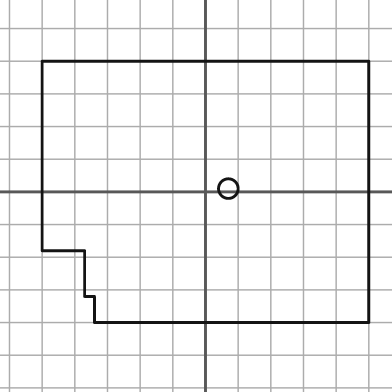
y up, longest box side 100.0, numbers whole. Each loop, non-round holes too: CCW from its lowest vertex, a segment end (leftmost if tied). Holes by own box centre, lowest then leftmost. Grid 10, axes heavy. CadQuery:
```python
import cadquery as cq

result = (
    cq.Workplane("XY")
    .moveTo(-34.0, -40.0)
    .lineTo(50.0, -40.0)
    .lineTo(50.0, 40.0)
    .lineTo(-50.0, 40.0)
    .lineTo(-50.0, -18.0)
    .lineTo(-37.0, -18.0)
    .lineTo(-37.0, -32.0)
    .lineTo(-34.0, -32.0)
    .close()
    .moveTo(7.0, 1.0)
    .circle(3.0)
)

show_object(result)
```